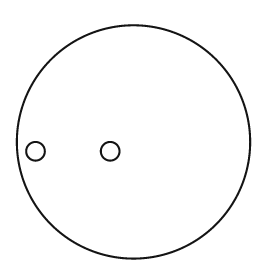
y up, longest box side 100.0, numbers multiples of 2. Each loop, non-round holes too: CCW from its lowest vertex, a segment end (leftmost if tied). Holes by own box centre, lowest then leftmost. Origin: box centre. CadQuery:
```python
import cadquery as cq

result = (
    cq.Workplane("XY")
    .moveTo(0.0, 0.0)
    .circle(50.0)
    .moveTo(-42.0, -4.0)
    .circle(4.0)
    .moveTo(-10.0, -4.0)
    .circle(4.0)
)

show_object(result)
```